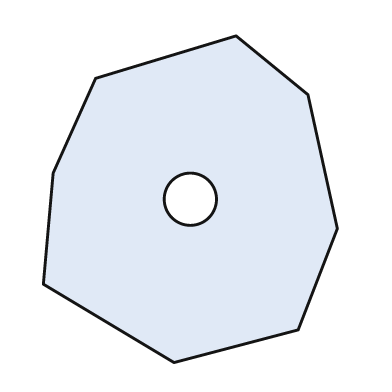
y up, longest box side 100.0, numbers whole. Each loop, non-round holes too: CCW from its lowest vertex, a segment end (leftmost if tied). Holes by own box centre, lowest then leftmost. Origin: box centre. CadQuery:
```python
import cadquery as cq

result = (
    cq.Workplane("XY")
    .moveTo(-5.0, -50.0)
    .lineTo(33.0, -40.0)
    .lineTo(45.0, -9.0)
    .lineTo(36.0, 32.0)
    .lineTo(14.0, 50.0)
    .lineTo(-29.0, 37.0)
    .lineTo(-42.0, 8.0)
    .lineTo(-45.0, -26.0)
    .close()
    .moveTo(0.0, 0.0)
    .circle(8.0)
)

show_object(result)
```